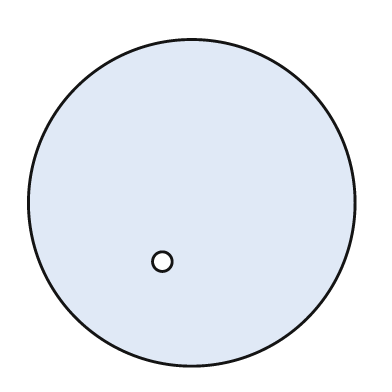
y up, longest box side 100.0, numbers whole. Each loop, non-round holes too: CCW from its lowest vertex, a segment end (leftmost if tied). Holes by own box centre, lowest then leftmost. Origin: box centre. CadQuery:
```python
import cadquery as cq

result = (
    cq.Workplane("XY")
    .moveTo(0.0, 0.0)
    .circle(50.0)
    .moveTo(-9.0, -18.0)
    .circle(3.0)
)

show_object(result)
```